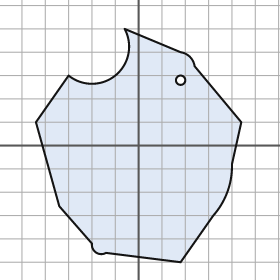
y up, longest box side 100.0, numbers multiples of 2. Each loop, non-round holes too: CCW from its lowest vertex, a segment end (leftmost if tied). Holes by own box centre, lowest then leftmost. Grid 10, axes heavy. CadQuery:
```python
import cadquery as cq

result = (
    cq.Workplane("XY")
    .moveTo(18.0, -50.0)
    .lineTo(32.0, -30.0)
    .threePointArc((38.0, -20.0), (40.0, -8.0))
    .lineTo(44.0, 10.0)
    .lineTo(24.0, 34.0)
    .threePointArc((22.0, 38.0), (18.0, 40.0))
    .lineTo(-6.0, 50.0)
    .threePointArc((-10.0, 30.0), (-30.0, 30.0))
    .lineTo(-44.0, 10.0)
    .lineTo(-34.0, -26.0)
    .lineTo(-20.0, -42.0)
    .threePointArc((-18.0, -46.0), (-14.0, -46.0))
    .close()
    .moveTo(18.0, 28.0)
    .circle(2.0)
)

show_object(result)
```